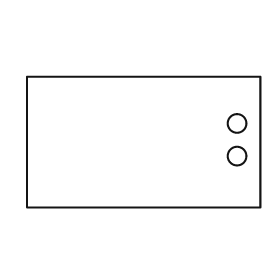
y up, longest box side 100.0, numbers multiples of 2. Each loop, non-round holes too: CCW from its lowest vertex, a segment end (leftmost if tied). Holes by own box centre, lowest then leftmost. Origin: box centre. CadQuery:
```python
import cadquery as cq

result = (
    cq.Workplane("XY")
    .moveTo(-50.0, -28.0)
    .lineTo(50.0, -28.0)
    .lineTo(50.0, 28.0)
    .lineTo(-50.0, 28.0)
    .close()
    .moveTo(40.0, -6.0)
    .circle(4.0)
    .moveTo(40.0, 8.0)
    .circle(4.0)
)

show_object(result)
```